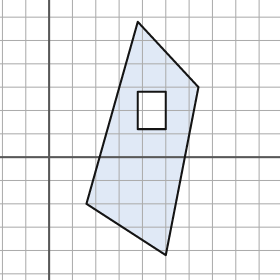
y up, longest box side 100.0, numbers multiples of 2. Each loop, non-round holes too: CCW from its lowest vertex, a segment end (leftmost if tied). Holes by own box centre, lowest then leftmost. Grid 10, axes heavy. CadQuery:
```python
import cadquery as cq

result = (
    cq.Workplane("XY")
    .moveTo(50.0, -42.0)
    .lineTo(64.0, 30.0)
    .lineTo(38.0, 58.0)
    .lineTo(16.0, -20.0)
    .close()
    .moveTo(38.0, 12.0)
    .lineTo(50.0, 12.0)
    .lineTo(50.0, 28.0)
    .lineTo(38.0, 28.0)
    .close()
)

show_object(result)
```